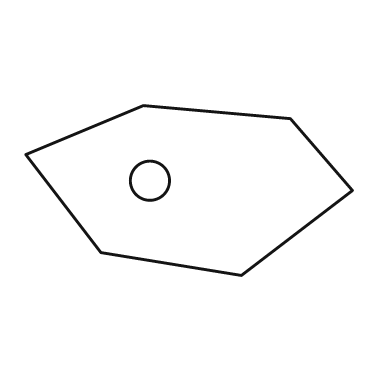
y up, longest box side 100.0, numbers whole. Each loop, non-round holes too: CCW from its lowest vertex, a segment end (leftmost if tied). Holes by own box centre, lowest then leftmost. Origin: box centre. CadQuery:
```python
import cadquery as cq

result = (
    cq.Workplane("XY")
    .moveTo(16.0, -26.0)
    .lineTo(50.0, 0.0)
    .lineTo(31.0, 22.0)
    .lineTo(-14.0, 26.0)
    .lineTo(-50.0, 11.0)
    .lineTo(-27.0, -19.0)
    .close()
    .moveTo(-12.0, 3.0)
    .circle(6.0)
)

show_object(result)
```